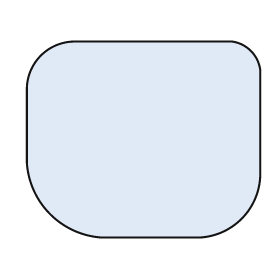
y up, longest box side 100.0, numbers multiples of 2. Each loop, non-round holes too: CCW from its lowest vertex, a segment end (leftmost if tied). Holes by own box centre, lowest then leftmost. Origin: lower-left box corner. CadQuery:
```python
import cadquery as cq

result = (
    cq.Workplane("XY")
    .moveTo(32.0, 0.0)
    .lineTo(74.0, 0.0)
    .threePointArc((92.0, 8.0), (100.0, 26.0))
    .lineTo(100.0, 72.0)
    .threePointArc((96.0, 80.0), (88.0, 84.0))
    .lineTo(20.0, 84.0)
    .threePointArc((6.0, 78.0), (0.0, 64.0))
    .lineTo(0.0, 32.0)
    .threePointArc((10.0, 10.0), (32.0, 0.0))
    .close()
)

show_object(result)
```